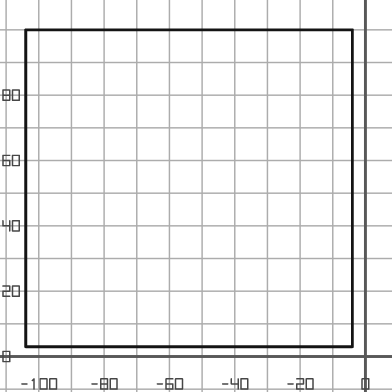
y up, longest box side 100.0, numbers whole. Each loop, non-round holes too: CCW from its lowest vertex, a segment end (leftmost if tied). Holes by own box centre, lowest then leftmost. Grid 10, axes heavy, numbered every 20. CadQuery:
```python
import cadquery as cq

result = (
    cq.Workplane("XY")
    .moveTo(-104.0, 3.0)
    .lineTo(-4.0, 3.0)
    .lineTo(-4.0, 100.0)
    .lineTo(-104.0, 100.0)
    .close()
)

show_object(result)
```